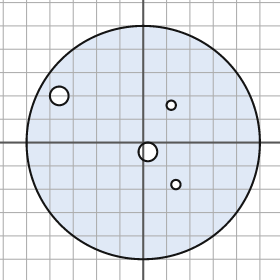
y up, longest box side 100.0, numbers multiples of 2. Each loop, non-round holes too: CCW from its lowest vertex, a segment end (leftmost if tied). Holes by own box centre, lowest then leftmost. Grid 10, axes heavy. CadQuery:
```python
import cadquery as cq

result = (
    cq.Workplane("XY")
    .moveTo(0.0, 0.0)
    .circle(50.0)
    .moveTo(14.0, -18.0)
    .circle(2.0)
    .moveTo(2.0, -4.0)
    .circle(4.0)
    .moveTo(12.0, 16.0)
    .circle(2.0)
    .moveTo(-36.0, 20.0)
    .circle(4.0)
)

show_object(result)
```